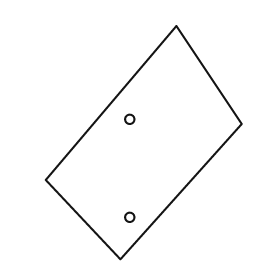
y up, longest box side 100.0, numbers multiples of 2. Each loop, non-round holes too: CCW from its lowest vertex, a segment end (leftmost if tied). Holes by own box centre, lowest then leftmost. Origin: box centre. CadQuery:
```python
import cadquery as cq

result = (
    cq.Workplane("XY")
    .moveTo(-10.0, -50.0)
    .lineTo(42.0, 8.0)
    .lineTo(14.0, 50.0)
    .lineTo(-42.0, -16.0)
    .close()
    .moveTo(-6.0, -32.0)
    .circle(2.0)
    .moveTo(-6.0, 10.0)
    .circle(2.0)
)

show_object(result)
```